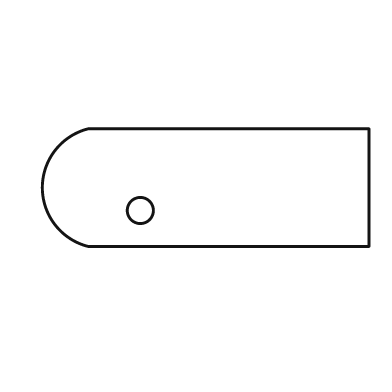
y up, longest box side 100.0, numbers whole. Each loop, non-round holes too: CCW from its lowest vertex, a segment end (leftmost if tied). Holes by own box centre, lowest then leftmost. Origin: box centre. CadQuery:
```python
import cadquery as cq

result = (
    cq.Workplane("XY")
    .moveTo(-36.0, -18.0)
    .lineTo(50.0, -18.0)
    .lineTo(50.0, 18.0)
    .lineTo(-36.0, 18.0)
    .threePointArc((-50.0, 0.0), (-36.0, -18.0))
    .close()
    .moveTo(-20.0, -7.0)
    .circle(4.0)
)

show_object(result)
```